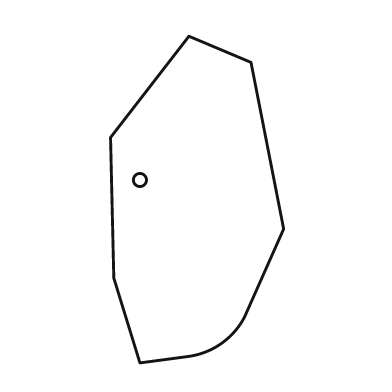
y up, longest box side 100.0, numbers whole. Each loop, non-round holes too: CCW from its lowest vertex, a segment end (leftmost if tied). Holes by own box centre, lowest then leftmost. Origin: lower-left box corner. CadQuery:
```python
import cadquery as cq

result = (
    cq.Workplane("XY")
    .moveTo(9.0, 0.0)
    .lineTo(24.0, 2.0)
    .threePointArc((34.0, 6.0), (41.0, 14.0))
    .lineTo(53.0, 41.0)
    .lineTo(43.0, 92.0)
    .lineTo(24.0, 100.0)
    .lineTo(0.0, 69.0)
    .lineTo(1.0, 26.0)
    .close()
    .moveTo(9.0, 56.0)
    .circle(2.0)
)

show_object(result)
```